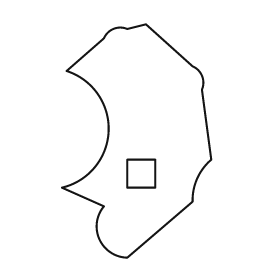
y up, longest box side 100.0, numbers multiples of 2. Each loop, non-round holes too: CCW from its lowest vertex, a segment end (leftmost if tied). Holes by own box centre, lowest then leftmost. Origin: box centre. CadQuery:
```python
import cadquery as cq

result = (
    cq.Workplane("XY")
    .moveTo(-4.0, -50.0)
    .lineTo(24.0, -26.0)
    .threePointArc((26.0, -16.0), (32.0, -8.0))
    .lineTo(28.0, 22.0)
    .threePointArc((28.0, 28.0), (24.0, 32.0))
    .lineTo(4.0, 50.0)
    .lineTo(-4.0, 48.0)
    .threePointArc((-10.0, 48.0), (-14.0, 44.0))
    .lineTo(-30.0, 30.0)
    .threePointArc((-12.0, 4.0), (-32.0, -20.0))
    .lineTo(-14.0, -28.0)
    .threePointArc((-16.0, -42.0), (-4.0, -50.0))
    .close()
    .moveTo(-4.0, -20.0)
    .lineTo(8.0, -20.0)
    .lineTo(8.0, -8.0)
    .lineTo(-4.0, -8.0)
    .close()
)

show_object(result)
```